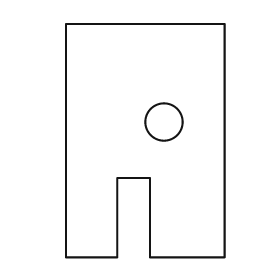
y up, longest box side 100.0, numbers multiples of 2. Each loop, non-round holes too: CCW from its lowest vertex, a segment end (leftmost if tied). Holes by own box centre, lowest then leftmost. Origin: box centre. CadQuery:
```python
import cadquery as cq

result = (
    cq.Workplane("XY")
    .moveTo(-34.0, -50.0)
    .lineTo(-12.0, -50.0)
    .lineTo(-12.0, -16.0)
    .lineTo(2.0, -16.0)
    .lineTo(2.0, -50.0)
    .lineTo(34.0, -50.0)
    .lineTo(34.0, 50.0)
    .lineTo(-34.0, 50.0)
    .close()
    .moveTo(8.0, 8.0)
    .circle(8.0)
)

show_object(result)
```